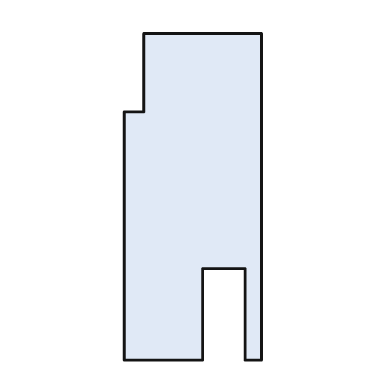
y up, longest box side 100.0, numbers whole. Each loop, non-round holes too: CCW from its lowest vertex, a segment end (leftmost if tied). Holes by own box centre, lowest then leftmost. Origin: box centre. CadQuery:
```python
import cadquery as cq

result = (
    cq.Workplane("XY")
    .moveTo(-21.0, -50.0)
    .lineTo(3.0, -50.0)
    .lineTo(3.0, -22.0)
    .lineTo(16.0, -22.0)
    .lineTo(16.0, -50.0)
    .lineTo(21.0, -50.0)
    .lineTo(21.0, 50.0)
    .lineTo(-15.0, 50.0)
    .lineTo(-15.0, 26.0)
    .lineTo(-21.0, 26.0)
    .close()
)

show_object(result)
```